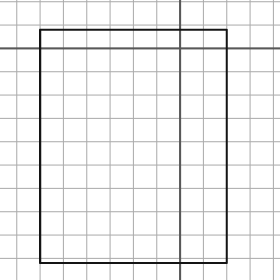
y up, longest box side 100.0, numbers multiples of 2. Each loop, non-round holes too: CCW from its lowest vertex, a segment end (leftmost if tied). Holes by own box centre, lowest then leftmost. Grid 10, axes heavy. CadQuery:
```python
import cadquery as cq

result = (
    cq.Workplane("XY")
    .moveTo(-60.0, -92.0)
    .lineTo(20.0, -92.0)
    .lineTo(20.0, 8.0)
    .lineTo(-60.0, 8.0)
    .close()
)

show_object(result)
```